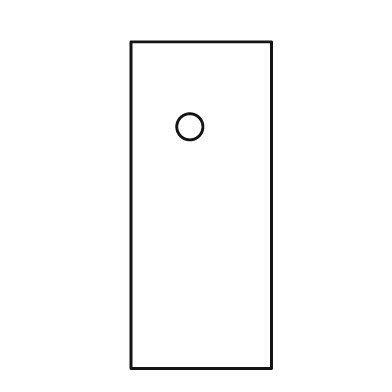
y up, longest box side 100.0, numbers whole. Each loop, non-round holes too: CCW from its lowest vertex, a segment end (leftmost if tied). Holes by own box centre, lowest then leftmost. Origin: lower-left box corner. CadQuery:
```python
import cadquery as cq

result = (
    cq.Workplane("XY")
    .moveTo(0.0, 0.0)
    .lineTo(43.0, 0.0)
    .lineTo(43.0, 100.0)
    .lineTo(0.0, 100.0)
    .close()
    .moveTo(18.0, 74.0)
    .circle(4.0)
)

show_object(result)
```